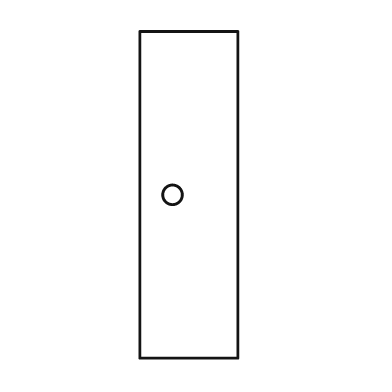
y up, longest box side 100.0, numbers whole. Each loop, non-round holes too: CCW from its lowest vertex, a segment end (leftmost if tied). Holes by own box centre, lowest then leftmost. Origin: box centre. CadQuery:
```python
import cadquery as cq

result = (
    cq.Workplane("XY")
    .moveTo(-15.0, -50.0)
    .lineTo(15.0, -50.0)
    .lineTo(15.0, 50.0)
    .lineTo(-15.0, 50.0)
    .close()
    .moveTo(-5.0, 0.0)
    .circle(3.0)
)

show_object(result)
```